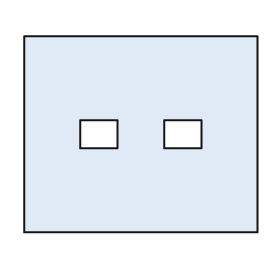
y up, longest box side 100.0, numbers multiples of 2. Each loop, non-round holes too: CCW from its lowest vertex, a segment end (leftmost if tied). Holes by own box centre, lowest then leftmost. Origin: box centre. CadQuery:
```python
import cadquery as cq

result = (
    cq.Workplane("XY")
    .moveTo(-50.0, -42.0)
    .lineTo(50.0, -42.0)
    .lineTo(50.0, 42.0)
    .lineTo(-50.0, 42.0)
    .close()
    .moveTo(-26.0, -6.0)
    .lineTo(-10.0, -6.0)
    .lineTo(-10.0, 6.0)
    .lineTo(-26.0, 6.0)
    .close()
    .moveTo(10.0, -6.0)
    .lineTo(26.0, -6.0)
    .lineTo(26.0, 6.0)
    .lineTo(10.0, 6.0)
    .close()
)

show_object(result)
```